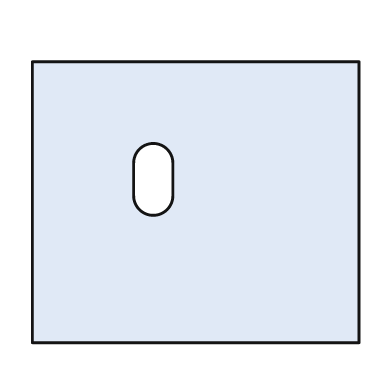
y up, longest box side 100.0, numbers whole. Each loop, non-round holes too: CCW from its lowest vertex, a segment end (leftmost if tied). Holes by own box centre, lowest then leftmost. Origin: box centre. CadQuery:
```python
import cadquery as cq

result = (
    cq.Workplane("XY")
    .moveTo(-50.0, -43.0)
    .lineTo(50.0, -43.0)
    .lineTo(50.0, 43.0)
    .lineTo(-50.0, 43.0)
    .close()
    .moveTo(-19.0, 2.0)
    .threePointArc((-13.0, -4.0), (-7.0, 2.0))
    .lineTo(-7.0, 12.0)
    .threePointArc((-13.0, 18.0), (-19.0, 12.0))
    .close()
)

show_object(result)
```